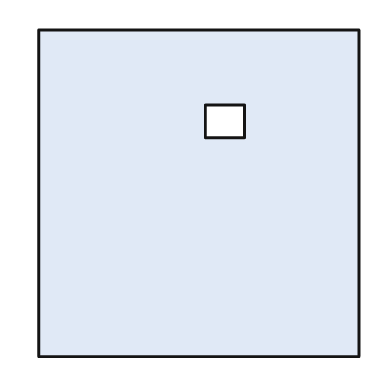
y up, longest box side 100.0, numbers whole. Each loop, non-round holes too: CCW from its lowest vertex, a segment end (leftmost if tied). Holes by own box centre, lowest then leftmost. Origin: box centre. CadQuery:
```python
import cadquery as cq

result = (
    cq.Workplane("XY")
    .moveTo(-49.0, -50.0)
    .lineTo(49.0, -50.0)
    .lineTo(49.0, 50.0)
    .lineTo(-49.0, 50.0)
    .close()
    .moveTo(2.0, 17.0)
    .lineTo(14.0, 17.0)
    .lineTo(14.0, 27.0)
    .lineTo(2.0, 27.0)
    .close()
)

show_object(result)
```